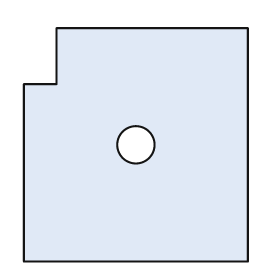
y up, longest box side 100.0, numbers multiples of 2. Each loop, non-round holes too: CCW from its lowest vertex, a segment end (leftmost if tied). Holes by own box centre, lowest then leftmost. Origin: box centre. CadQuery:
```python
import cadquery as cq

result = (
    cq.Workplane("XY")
    .moveTo(-48.0, -50.0)
    .lineTo(48.0, -50.0)
    .lineTo(48.0, 50.0)
    .lineTo(-34.0, 50.0)
    .lineTo(-34.0, 26.0)
    .lineTo(-48.0, 26.0)
    .close()
    .moveTo(0.0, 0.0)
    .circle(8.0)
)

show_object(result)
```